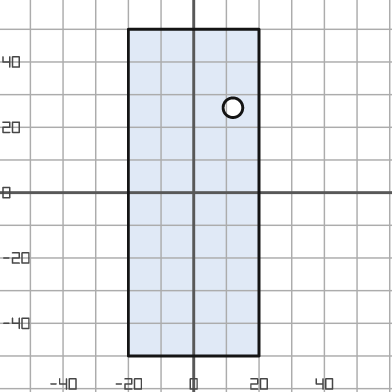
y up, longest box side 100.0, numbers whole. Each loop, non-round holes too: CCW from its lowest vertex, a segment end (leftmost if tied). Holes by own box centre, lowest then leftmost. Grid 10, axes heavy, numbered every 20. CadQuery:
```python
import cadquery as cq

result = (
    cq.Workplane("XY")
    .moveTo(-20.0, -50.0)
    .lineTo(20.0, -50.0)
    .lineTo(20.0, 50.0)
    .lineTo(-20.0, 50.0)
    .close()
    .moveTo(12.0, 26.0)
    .circle(3.0)
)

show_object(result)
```